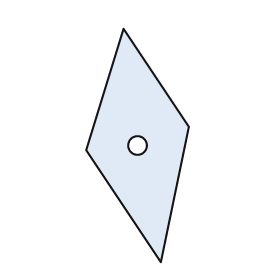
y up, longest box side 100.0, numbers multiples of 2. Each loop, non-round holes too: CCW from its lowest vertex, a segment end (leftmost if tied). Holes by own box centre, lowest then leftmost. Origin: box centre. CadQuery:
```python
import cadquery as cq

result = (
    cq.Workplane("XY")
    .moveTo(10.0, -50.0)
    .lineTo(22.0, 8.0)
    .lineTo(-6.0, 50.0)
    .lineTo(-22.0, -2.0)
    .close()
    .moveTo(0.0, 0.0)
    .circle(4.0)
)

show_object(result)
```